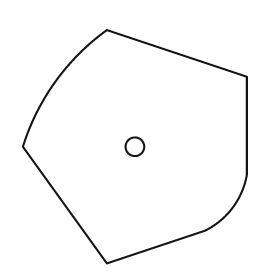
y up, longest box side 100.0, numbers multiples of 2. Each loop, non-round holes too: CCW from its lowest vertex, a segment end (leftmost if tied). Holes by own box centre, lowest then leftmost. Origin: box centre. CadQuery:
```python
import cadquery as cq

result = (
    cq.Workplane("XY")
    .moveTo(-12.0, -50.0)
    .lineTo(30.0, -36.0)
    .threePointArc((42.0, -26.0), (48.0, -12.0))
    .lineTo(48.0, 30.0)
    .lineTo(-12.0, 50.0)
    .threePointArc((-34.0, 28.0), (-48.0, 0.0))
    .close()
    .moveTo(0.0, 0.0)
    .circle(4.0)
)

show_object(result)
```